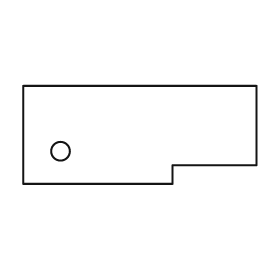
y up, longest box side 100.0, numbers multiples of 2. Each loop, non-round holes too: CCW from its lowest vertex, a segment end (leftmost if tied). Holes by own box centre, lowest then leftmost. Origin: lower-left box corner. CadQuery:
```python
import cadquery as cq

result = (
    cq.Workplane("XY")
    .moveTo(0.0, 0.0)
    .lineTo(64.0, 0.0)
    .lineTo(64.0, 8.0)
    .lineTo(100.0, 8.0)
    .lineTo(100.0, 42.0)
    .lineTo(0.0, 42.0)
    .close()
    .moveTo(16.0, 14.0)
    .circle(4.0)
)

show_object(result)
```